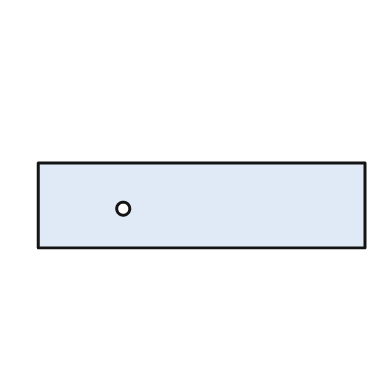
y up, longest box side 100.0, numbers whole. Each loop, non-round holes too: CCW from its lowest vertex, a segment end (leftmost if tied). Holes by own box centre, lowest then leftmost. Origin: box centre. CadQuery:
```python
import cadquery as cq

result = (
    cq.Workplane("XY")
    .moveTo(-50.0, -13.0)
    .lineTo(50.0, -13.0)
    .lineTo(50.0, 13.0)
    .lineTo(-50.0, 13.0)
    .close()
    .moveTo(-24.0, -1.0)
    .circle(2.0)
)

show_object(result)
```